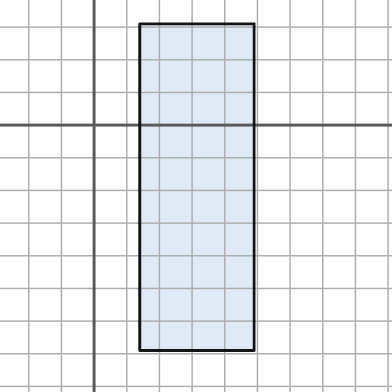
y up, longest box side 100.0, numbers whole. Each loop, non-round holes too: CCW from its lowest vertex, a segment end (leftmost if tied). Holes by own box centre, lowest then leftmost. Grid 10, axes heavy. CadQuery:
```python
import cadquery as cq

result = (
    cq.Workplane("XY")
    .moveTo(14.0, -69.0)
    .lineTo(49.0, -69.0)
    .lineTo(49.0, 31.0)
    .lineTo(14.0, 31.0)
    .close()
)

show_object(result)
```